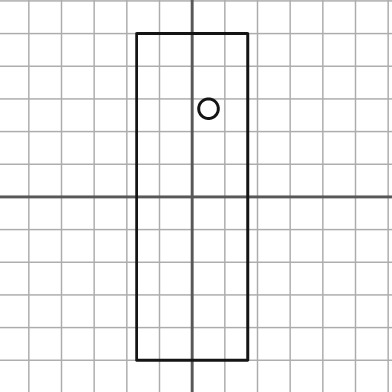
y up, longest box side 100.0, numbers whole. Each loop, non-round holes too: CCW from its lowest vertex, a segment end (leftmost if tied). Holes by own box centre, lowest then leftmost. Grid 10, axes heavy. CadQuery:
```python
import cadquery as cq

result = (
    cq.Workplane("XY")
    .moveTo(-17.0, -50.0)
    .lineTo(17.0, -50.0)
    .lineTo(17.0, 50.0)
    .lineTo(-17.0, 50.0)
    .close()
    .moveTo(5.0, 27.0)
    .circle(3.0)
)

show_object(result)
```